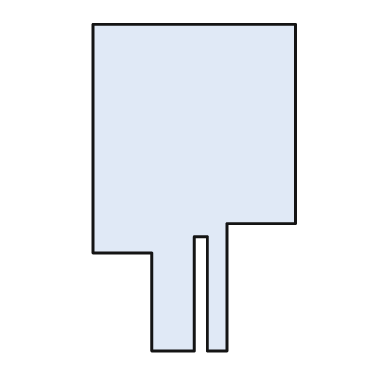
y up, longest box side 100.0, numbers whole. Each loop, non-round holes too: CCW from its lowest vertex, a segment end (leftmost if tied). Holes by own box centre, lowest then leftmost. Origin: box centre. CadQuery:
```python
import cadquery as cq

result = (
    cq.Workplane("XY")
    .moveTo(-13.0, -50.0)
    .lineTo(0.0, -50.0)
    .lineTo(0.0, -15.0)
    .lineTo(4.0, -15.0)
    .lineTo(4.0, -50.0)
    .lineTo(10.0, -50.0)
    .lineTo(10.0, -11.0)
    .lineTo(31.0, -11.0)
    .lineTo(31.0, 50.0)
    .lineTo(-31.0, 50.0)
    .lineTo(-31.0, -20.0)
    .lineTo(-13.0, -20.0)
    .close()
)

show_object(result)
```